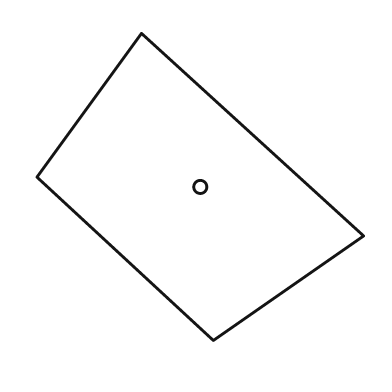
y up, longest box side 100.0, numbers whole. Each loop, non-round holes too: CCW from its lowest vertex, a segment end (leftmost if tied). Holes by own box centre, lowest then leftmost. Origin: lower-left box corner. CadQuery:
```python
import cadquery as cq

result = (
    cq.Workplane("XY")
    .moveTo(54.0, 0.0)
    .lineTo(100.0, 32.0)
    .lineTo(32.0, 94.0)
    .lineTo(0.0, 50.0)
    .close()
    .moveTo(50.0, 47.0)
    .circle(2.0)
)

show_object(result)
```